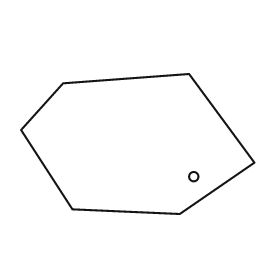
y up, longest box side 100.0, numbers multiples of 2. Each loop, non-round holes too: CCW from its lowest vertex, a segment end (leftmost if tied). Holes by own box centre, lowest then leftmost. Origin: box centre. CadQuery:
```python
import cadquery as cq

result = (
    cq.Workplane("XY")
    .moveTo(18.0, -30.0)
    .lineTo(50.0, -8.0)
    .lineTo(22.0, 30.0)
    .lineTo(-32.0, 26.0)
    .lineTo(-50.0, 6.0)
    .lineTo(-28.0, -28.0)
    .close()
    .moveTo(24.0, -14.0)
    .circle(2.0)
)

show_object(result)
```